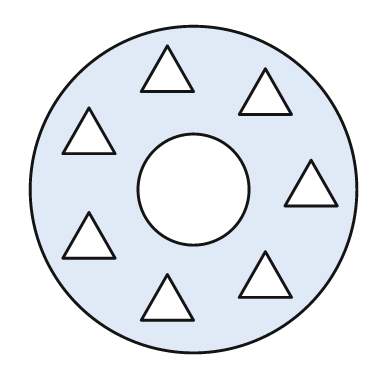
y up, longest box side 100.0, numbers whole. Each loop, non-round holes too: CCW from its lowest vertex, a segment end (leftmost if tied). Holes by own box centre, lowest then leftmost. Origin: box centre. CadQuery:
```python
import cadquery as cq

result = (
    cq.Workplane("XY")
    .moveTo(0.0, 0.0)
    .circle(50.0)
    .moveTo(-16.0, -40.0)
    .lineTo(0.0, -40.0)
    .lineTo(-8.0, -26.0)
    .close()
    .moveTo(14.0, -33.0)
    .lineTo(30.0, -33.0)
    .lineTo(22.0, -19.0)
    .close()
    .moveTo(-40.0, -21.0)
    .lineTo(-24.0, -21.0)
    .lineTo(-32.0, -7.0)
    .close()
    .moveTo(0.0, 0.0)
    .circle(17.0)
    .moveTo(28.0, -5.0)
    .lineTo(44.0, -5.0)
    .lineTo(36.0, 9.0)
    .close()
    .moveTo(-40.0, 11.0)
    .lineTo(-24.0, 11.0)
    .lineTo(-32.0, 25.0)
    .close()
    .moveTo(14.0, 23.0)
    .lineTo(30.0, 23.0)
    .lineTo(22.0, 37.0)
    .close()
    .moveTo(-16.0, 30.0)
    .lineTo(0.0, 30.0)
    .lineTo(-8.0, 44.0)
    .close()
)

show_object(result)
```